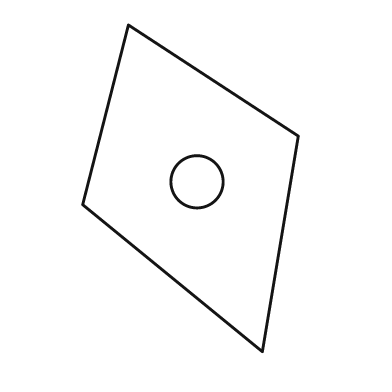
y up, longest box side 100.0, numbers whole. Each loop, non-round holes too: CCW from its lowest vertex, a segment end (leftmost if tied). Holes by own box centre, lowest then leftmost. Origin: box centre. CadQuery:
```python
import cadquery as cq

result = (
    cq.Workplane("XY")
    .moveTo(22.0, -50.0)
    .lineTo(33.0, 16.0)
    .lineTo(-19.0, 50.0)
    .lineTo(-33.0, -5.0)
    .close()
    .moveTo(2.0, 2.0)
    .circle(8.0)
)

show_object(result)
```